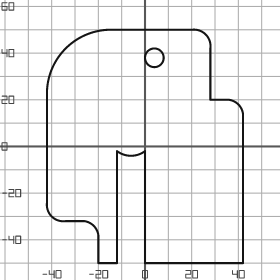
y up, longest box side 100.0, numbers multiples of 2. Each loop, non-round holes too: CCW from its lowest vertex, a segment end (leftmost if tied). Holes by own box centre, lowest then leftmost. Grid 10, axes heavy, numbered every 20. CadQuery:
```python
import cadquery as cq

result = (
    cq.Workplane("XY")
    .moveTo(-20.0, -50.0)
    .lineTo(-12.0, -50.0)
    .lineTo(-12.0, -2.0)
    .threePointArc((-6.0, -4.0), (0.0, -2.0))
    .lineTo(0.0, -50.0)
    .lineTo(42.0, -50.0)
    .lineTo(42.0, 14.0)
    .threePointArc((40.0, 18.0), (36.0, 20.0))
    .lineTo(28.0, 20.0)
    .lineTo(28.0, 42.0)
    .threePointArc((26.0, 48.0), (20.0, 50.0))
    .lineTo(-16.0, 50.0)
    .threePointArc((-34.0, 42.0), (-42.0, 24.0))
    .lineTo(-42.0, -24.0)
    .threePointArc((-40.0, -30.0), (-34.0, -32.0))
    .lineTo(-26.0, -32.0)
    .threePointArc((-22.0, -34.0), (-20.0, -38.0))
    .close()
    .moveTo(4.0, 38.0)
    .circle(4.0)
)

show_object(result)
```